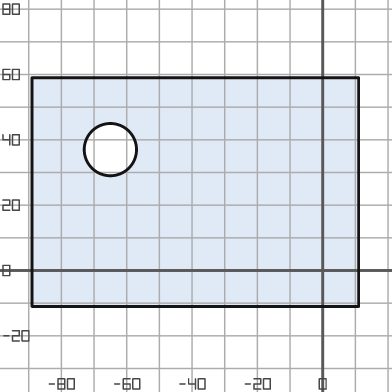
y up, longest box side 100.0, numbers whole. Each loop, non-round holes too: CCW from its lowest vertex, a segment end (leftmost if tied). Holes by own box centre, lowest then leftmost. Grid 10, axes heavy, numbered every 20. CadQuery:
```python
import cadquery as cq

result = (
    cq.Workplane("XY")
    .moveTo(-89.0, -11.0)
    .lineTo(11.0, -11.0)
    .lineTo(11.0, 59.0)
    .lineTo(-89.0, 59.0)
    .close()
    .moveTo(-65.0, 37.0)
    .circle(8.0)
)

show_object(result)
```